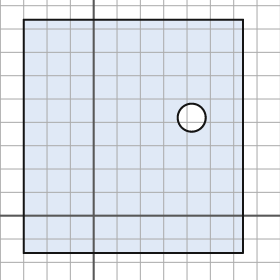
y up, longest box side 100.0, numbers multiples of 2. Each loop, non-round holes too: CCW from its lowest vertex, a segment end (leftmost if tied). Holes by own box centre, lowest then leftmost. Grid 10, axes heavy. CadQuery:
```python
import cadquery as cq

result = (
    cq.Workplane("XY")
    .moveTo(-30.0, -16.0)
    .lineTo(64.0, -16.0)
    .lineTo(64.0, 84.0)
    .lineTo(-30.0, 84.0)
    .close()
    .moveTo(42.0, 42.0)
    .circle(6.0)
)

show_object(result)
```